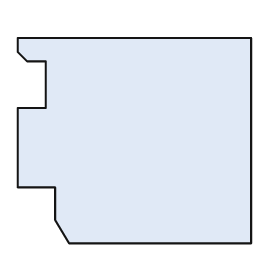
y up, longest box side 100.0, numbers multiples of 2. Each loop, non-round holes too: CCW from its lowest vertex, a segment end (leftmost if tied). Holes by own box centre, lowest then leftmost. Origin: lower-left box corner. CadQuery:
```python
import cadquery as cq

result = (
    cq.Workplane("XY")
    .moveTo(22.0, 0.0)
    .lineTo(100.0, 0.0)
    .lineTo(100.0, 88.0)
    .lineTo(0.0, 88.0)
    .lineTo(0.0, 82.0)
    .lineTo(4.0, 78.0)
    .lineTo(12.0, 78.0)
    .lineTo(12.0, 58.0)
    .lineTo(0.0, 58.0)
    .lineTo(0.0, 24.0)
    .lineTo(16.0, 24.0)
    .lineTo(16.0, 10.0)
    .close()
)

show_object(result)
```